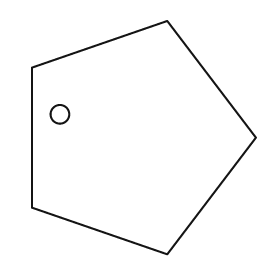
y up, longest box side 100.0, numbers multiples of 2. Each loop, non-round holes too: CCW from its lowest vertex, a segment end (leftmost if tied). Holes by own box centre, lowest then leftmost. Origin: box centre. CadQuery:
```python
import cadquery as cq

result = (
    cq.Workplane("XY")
    .moveTo(10.0, -50.0)
    .lineTo(48.0, 0.0)
    .lineTo(10.0, 50.0)
    .lineTo(-48.0, 30.0)
    .lineTo(-48.0, -30.0)
    .close()
    .moveTo(-36.0, 10.0)
    .circle(4.0)
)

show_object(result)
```